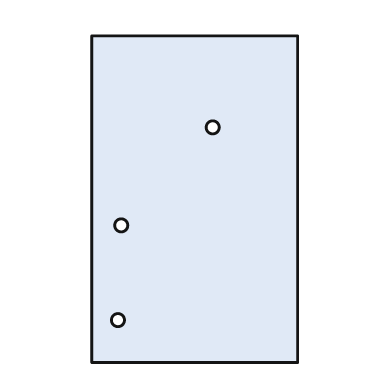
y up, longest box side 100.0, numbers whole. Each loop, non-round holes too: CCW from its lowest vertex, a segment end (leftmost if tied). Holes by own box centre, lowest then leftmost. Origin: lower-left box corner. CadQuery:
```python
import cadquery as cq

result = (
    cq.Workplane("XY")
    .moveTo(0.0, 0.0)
    .lineTo(63.0, 0.0)
    .lineTo(63.0, 100.0)
    .lineTo(0.0, 100.0)
    .close()
    .moveTo(8.0, 13.0)
    .circle(2.0)
    .moveTo(9.0, 42.0)
    .circle(2.0)
    .moveTo(37.0, 72.0)
    .circle(2.0)
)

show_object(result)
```